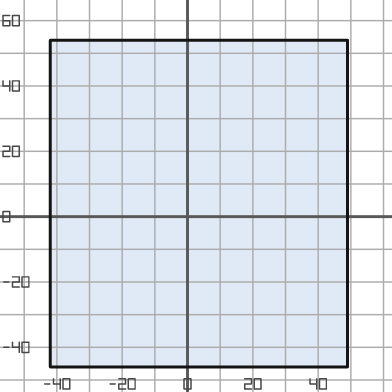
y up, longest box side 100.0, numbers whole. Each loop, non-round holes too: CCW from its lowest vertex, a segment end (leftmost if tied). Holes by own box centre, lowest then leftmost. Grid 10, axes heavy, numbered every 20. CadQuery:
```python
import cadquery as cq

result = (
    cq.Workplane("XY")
    .moveTo(-42.0, -46.0)
    .lineTo(49.0, -46.0)
    .lineTo(49.0, 54.0)
    .lineTo(-42.0, 54.0)
    .close()
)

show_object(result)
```